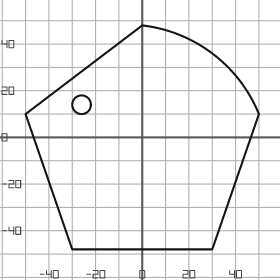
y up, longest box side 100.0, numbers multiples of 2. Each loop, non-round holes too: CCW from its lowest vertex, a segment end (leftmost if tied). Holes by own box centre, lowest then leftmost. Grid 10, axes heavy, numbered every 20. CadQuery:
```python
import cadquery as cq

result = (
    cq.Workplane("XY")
    .moveTo(-30.0, -48.0)
    .lineTo(30.0, -48.0)
    .lineTo(50.0, 10.0)
    .threePointArc((30.0, 36.0), (0.0, 48.0))
    .lineTo(-50.0, 10.0)
    .close()
    .moveTo(-26.0, 14.0)
    .circle(4.0)
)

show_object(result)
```